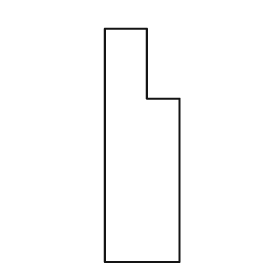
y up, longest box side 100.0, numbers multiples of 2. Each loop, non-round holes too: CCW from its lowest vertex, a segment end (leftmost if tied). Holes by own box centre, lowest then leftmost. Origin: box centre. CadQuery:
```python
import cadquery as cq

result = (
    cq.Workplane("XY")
    .moveTo(-16.0, -50.0)
    .lineTo(16.0, -50.0)
    .lineTo(16.0, 20.0)
    .lineTo(2.0, 20.0)
    .lineTo(2.0, 50.0)
    .lineTo(-16.0, 50.0)
    .close()
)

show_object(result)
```